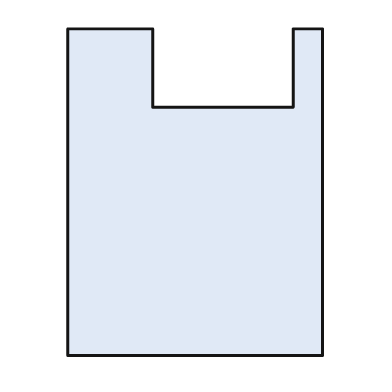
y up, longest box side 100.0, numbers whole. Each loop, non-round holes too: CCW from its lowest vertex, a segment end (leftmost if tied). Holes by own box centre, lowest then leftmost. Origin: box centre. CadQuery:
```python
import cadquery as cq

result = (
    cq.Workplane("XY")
    .moveTo(-39.0, -50.0)
    .lineTo(39.0, -50.0)
    .lineTo(39.0, 50.0)
    .lineTo(30.0, 50.0)
    .lineTo(30.0, 26.0)
    .lineTo(-13.0, 26.0)
    .lineTo(-13.0, 50.0)
    .lineTo(-39.0, 50.0)
    .close()
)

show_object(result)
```